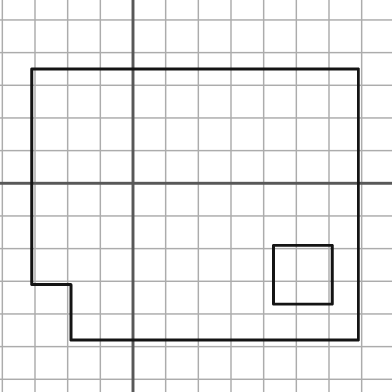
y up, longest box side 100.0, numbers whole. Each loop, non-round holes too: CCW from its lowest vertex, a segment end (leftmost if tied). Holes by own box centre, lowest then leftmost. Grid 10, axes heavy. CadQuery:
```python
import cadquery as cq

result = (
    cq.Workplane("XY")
    .moveTo(-19.0, -48.0)
    .lineTo(69.0, -48.0)
    .lineTo(69.0, 35.0)
    .lineTo(-31.0, 35.0)
    .lineTo(-31.0, -31.0)
    .lineTo(-19.0, -31.0)
    .close()
    .moveTo(43.0, -37.0)
    .lineTo(61.0, -37.0)
    .lineTo(61.0, -19.0)
    .lineTo(43.0, -19.0)
    .close()
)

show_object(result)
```